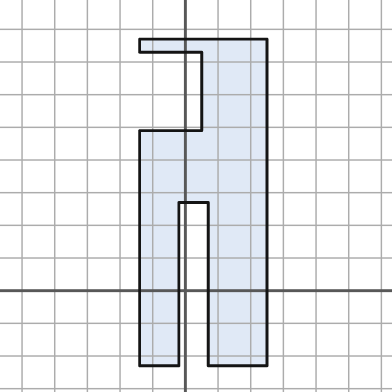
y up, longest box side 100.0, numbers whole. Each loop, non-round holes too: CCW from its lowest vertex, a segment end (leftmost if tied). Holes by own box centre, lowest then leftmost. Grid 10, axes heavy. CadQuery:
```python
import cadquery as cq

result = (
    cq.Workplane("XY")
    .moveTo(-14.0, -23.0)
    .lineTo(-2.0, -23.0)
    .lineTo(-2.0, 27.0)
    .lineTo(7.0, 27.0)
    .lineTo(7.0, -23.0)
    .lineTo(25.0, -23.0)
    .lineTo(25.0, 77.0)
    .lineTo(-14.0, 77.0)
    .lineTo(-14.0, 73.0)
    .lineTo(5.0, 73.0)
    .lineTo(5.0, 49.0)
    .lineTo(-14.0, 49.0)
    .close()
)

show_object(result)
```